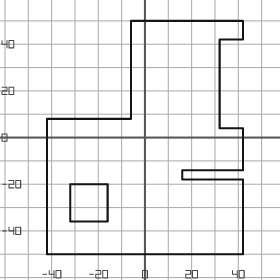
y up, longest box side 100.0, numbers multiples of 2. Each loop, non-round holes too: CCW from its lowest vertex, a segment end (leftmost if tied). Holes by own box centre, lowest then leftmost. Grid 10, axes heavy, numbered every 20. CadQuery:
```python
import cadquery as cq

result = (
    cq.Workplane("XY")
    .moveTo(-42.0, -50.0)
    .lineTo(42.0, -50.0)
    .lineTo(42.0, -18.0)
    .lineTo(16.0, -18.0)
    .lineTo(16.0, -14.0)
    .lineTo(42.0, -14.0)
    .lineTo(42.0, 4.0)
    .lineTo(32.0, 4.0)
    .lineTo(32.0, 42.0)
    .lineTo(42.0, 42.0)
    .lineTo(42.0, 50.0)
    .lineTo(-6.0, 50.0)
    .lineTo(-6.0, 8.0)
    .lineTo(-42.0, 8.0)
    .close()
    .moveTo(-32.0, -36.0)
    .lineTo(-16.0, -36.0)
    .lineTo(-16.0, -20.0)
    .lineTo(-32.0, -20.0)
    .close()
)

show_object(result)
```